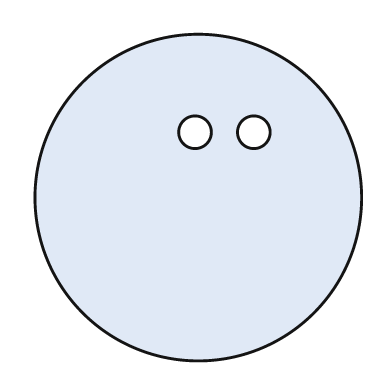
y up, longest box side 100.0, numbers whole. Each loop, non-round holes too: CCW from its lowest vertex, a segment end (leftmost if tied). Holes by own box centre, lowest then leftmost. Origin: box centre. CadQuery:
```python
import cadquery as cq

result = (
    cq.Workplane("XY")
    .moveTo(0.0, 0.0)
    .circle(50.0)
    .moveTo(-1.0, 20.0)
    .circle(5.0)
    .moveTo(17.0, 20.0)
    .circle(5.0)
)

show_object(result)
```